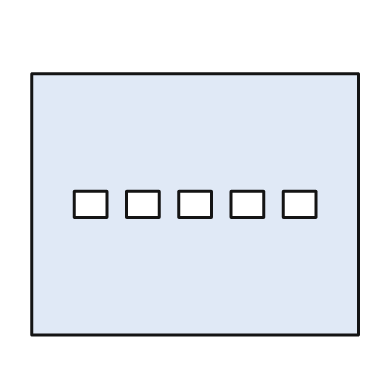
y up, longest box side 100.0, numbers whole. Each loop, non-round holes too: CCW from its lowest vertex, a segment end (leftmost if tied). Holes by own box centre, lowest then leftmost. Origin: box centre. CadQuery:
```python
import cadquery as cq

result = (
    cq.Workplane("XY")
    .moveTo(-50.0, -40.0)
    .lineTo(50.0, -40.0)
    .lineTo(50.0, 40.0)
    .lineTo(-50.0, 40.0)
    .close()
    .moveTo(-37.0, -4.0)
    .lineTo(-27.0, -4.0)
    .lineTo(-27.0, 4.0)
    .lineTo(-37.0, 4.0)
    .close()
    .moveTo(-21.0, -4.0)
    .lineTo(-11.0, -4.0)
    .lineTo(-11.0, 4.0)
    .lineTo(-21.0, 4.0)
    .close()
    .moveTo(-5.0, -4.0)
    .lineTo(5.0, -4.0)
    .lineTo(5.0, 4.0)
    .lineTo(-5.0, 4.0)
    .close()
    .moveTo(11.0, -4.0)
    .lineTo(21.0, -4.0)
    .lineTo(21.0, 4.0)
    .lineTo(11.0, 4.0)
    .close()
    .moveTo(27.0, -4.0)
    .lineTo(37.0, -4.0)
    .lineTo(37.0, 4.0)
    .lineTo(27.0, 4.0)
    .close()
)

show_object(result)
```